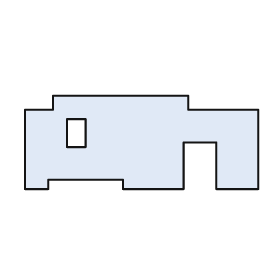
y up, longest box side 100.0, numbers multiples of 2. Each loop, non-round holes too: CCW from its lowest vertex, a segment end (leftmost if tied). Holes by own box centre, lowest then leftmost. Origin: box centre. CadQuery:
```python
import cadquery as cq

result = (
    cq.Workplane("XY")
    .moveTo(-50.0, -20.0)
    .lineTo(-40.0, -20.0)
    .lineTo(-40.0, -16.0)
    .lineTo(-8.0, -16.0)
    .lineTo(-8.0, -20.0)
    .lineTo(18.0, -20.0)
    .lineTo(18.0, 0.0)
    .lineTo(32.0, 0.0)
    .lineTo(32.0, -20.0)
    .lineTo(50.0, -20.0)
    .lineTo(50.0, 14.0)
    .lineTo(20.0, 14.0)
    .lineTo(20.0, 20.0)
    .lineTo(-38.0, 20.0)
    .lineTo(-38.0, 14.0)
    .lineTo(-50.0, 14.0)
    .close()
    .moveTo(-32.0, -2.0)
    .lineTo(-24.0, -2.0)
    .lineTo(-24.0, 10.0)
    .lineTo(-32.0, 10.0)
    .close()
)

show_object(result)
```